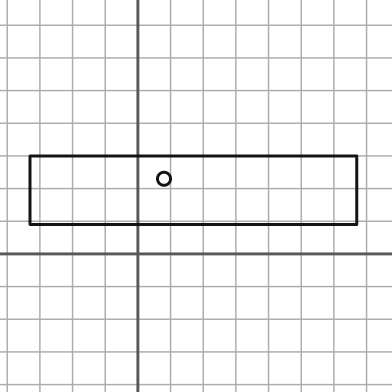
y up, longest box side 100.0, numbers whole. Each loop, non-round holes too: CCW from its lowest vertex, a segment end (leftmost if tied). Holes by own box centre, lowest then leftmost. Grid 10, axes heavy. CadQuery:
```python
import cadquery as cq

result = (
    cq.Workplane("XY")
    .moveTo(-33.0, 9.0)
    .lineTo(67.0, 9.0)
    .lineTo(67.0, 30.0)
    .lineTo(-33.0, 30.0)
    .close()
    .moveTo(8.0, 23.0)
    .circle(2.0)
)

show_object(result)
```